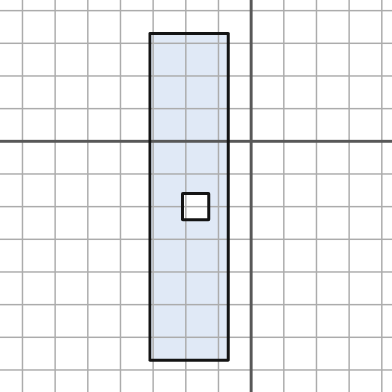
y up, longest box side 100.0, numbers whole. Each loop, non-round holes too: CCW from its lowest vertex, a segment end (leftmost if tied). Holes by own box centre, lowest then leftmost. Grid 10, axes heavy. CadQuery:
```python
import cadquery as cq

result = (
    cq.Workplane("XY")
    .moveTo(-31.0, -67.0)
    .lineTo(-7.0, -67.0)
    .lineTo(-7.0, 33.0)
    .lineTo(-31.0, 33.0)
    .close()
    .moveTo(-21.0, -24.0)
    .lineTo(-13.0, -24.0)
    .lineTo(-13.0, -16.0)
    .lineTo(-21.0, -16.0)
    .close()
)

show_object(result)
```